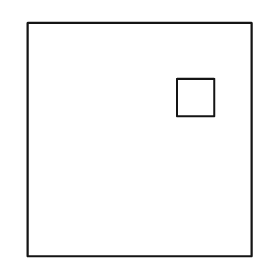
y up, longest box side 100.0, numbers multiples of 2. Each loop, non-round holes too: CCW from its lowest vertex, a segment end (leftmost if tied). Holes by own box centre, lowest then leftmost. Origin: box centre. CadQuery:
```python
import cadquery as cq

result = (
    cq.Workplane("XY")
    .moveTo(-48.0, -50.0)
    .lineTo(48.0, -50.0)
    .lineTo(48.0, 50.0)
    .lineTo(-48.0, 50.0)
    .close()
    .moveTo(16.0, 10.0)
    .lineTo(32.0, 10.0)
    .lineTo(32.0, 26.0)
    .lineTo(16.0, 26.0)
    .close()
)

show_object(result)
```